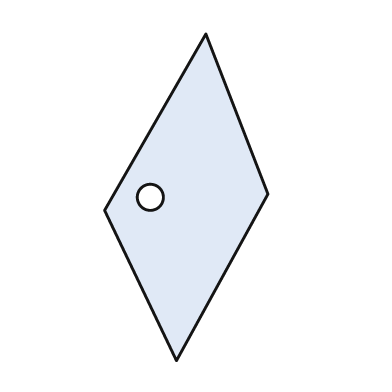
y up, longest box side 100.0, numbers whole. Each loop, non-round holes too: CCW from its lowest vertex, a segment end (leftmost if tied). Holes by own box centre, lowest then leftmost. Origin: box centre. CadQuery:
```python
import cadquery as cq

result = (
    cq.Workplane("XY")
    .moveTo(-3.0, -50.0)
    .lineTo(25.0, 1.0)
    .lineTo(6.0, 50.0)
    .lineTo(-25.0, -4.0)
    .close()
    .moveTo(-11.0, 0.0)
    .circle(4.0)
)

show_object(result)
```